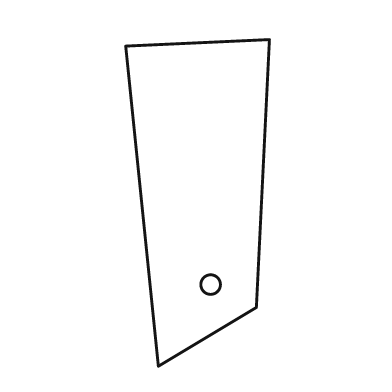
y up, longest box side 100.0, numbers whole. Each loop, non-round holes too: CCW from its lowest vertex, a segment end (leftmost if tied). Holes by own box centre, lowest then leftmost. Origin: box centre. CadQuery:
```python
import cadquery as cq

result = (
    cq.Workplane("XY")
    .moveTo(-12.0, -50.0)
    .lineTo(18.0, -32.0)
    .lineTo(22.0, 50.0)
    .lineTo(-22.0, 48.0)
    .close()
    .moveTo(4.0, -25.0)
    .circle(3.0)
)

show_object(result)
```